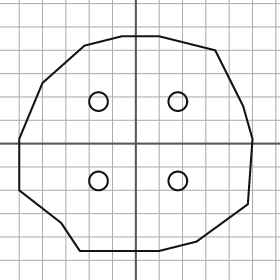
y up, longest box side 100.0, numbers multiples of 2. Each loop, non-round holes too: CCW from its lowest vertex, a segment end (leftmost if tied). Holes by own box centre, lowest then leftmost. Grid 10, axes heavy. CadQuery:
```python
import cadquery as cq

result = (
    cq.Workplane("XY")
    .moveTo(-24.0, -46.0)
    .lineTo(10.0, -46.0)
    .lineTo(26.0, -42.0)
    .lineTo(48.0, -26.0)
    .lineTo(50.0, 2.0)
    .lineTo(46.0, 16.0)
    .lineTo(34.0, 40.0)
    .lineTo(10.0, 46.0)
    .lineTo(-6.0, 46.0)
    .lineTo(-22.0, 42.0)
    .lineTo(-40.0, 26.0)
    .lineTo(-50.0, 2.0)
    .lineTo(-50.0, -20.0)
    .lineTo(-32.0, -34.0)
    .close()
    .moveTo(-16.0, -16.0)
    .circle(4.0)
    .moveTo(18.0, -16.0)
    .circle(4.0)
    .moveTo(-16.0, 18.0)
    .circle(4.0)
    .moveTo(18.0, 18.0)
    .circle(4.0)
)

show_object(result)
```